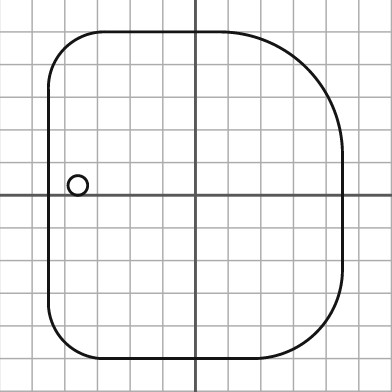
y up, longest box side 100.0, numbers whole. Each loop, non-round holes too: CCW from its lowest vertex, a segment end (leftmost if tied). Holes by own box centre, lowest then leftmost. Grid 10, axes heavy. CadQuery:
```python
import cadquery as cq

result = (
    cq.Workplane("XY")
    .moveTo(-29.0, -50.0)
    .lineTo(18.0, -50.0)
    .threePointArc((37.0, -42.0), (45.0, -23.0))
    .lineTo(45.0, 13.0)
    .threePointArc((34.0, 39.0), (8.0, 50.0))
    .lineTo(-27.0, 50.0)
    .threePointArc((-40.0, 45.0), (-45.0, 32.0))
    .lineTo(-45.0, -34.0)
    .threePointArc((-40.0, -45.0), (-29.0, -50.0))
    .close()
    .moveTo(-36.0, 3.0)
    .circle(3.0)
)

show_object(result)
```